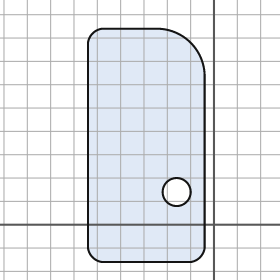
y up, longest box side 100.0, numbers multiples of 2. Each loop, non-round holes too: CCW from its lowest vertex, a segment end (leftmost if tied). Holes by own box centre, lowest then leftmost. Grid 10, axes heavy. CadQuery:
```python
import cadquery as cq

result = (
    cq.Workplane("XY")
    .moveTo(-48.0, -16.0)
    .lineTo(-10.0, -16.0)
    .threePointArc((-6.0, -14.0), (-4.0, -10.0))
    .lineTo(-4.0, 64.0)
    .threePointArc((-10.0, 78.0), (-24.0, 84.0))
    .lineTo(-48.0, 84.0)
    .threePointArc((-52.0, 82.0), (-54.0, 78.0))
    .lineTo(-54.0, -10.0)
    .threePointArc((-52.0, -14.0), (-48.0, -16.0))
    .close()
    .moveTo(-16.0, 14.0)
    .circle(6.0)
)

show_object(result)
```